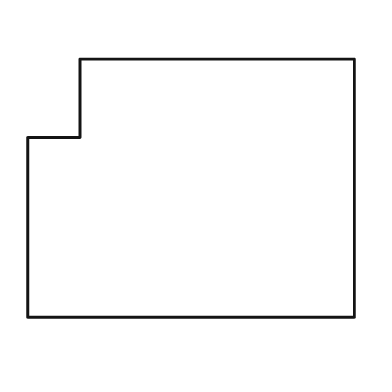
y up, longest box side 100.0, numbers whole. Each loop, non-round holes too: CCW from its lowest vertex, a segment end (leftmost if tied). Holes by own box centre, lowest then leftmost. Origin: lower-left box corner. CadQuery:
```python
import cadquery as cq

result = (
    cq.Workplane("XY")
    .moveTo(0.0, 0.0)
    .lineTo(100.0, 0.0)
    .lineTo(100.0, 79.0)
    .lineTo(16.0, 79.0)
    .lineTo(16.0, 55.0)
    .lineTo(0.0, 55.0)
    .close()
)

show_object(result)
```